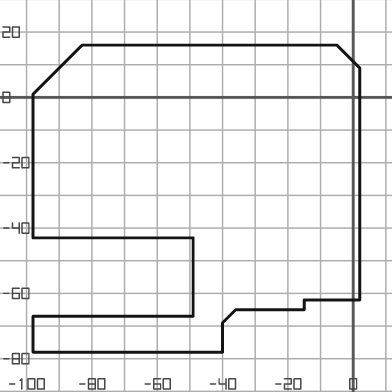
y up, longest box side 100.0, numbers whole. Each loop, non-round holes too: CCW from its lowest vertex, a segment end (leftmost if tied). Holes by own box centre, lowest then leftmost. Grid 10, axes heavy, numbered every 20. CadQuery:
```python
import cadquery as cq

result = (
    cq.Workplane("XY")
    .moveTo(-98.0, -78.0)
    .lineTo(-40.0, -78.0)
    .lineTo(-40.0, -69.0)
    .lineTo(-36.0, -65.0)
    .lineTo(-15.0, -65.0)
    .lineTo(-15.0, -62.0)
    .lineTo(2.0, -62.0)
    .lineTo(2.0, 9.0)
    .lineTo(-5.0, 16.0)
    .lineTo(-83.0, 16.0)
    .lineTo(-98.0, 1.0)
    .lineTo(-98.0, -43.0)
    .lineTo(-49.0, -43.0)
    .lineTo(-49.0, -67.0)
    .lineTo(-98.0, -67.0)
    .close()
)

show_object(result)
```